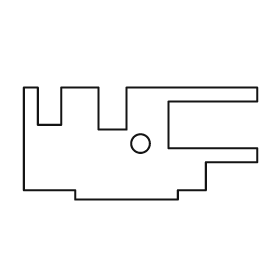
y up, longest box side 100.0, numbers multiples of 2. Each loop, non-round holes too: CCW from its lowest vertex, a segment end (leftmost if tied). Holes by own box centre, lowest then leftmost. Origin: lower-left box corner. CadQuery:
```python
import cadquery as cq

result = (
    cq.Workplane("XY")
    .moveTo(22.0, 0.0)
    .lineTo(66.0, 0.0)
    .lineTo(66.0, 4.0)
    .lineTo(78.0, 4.0)
    .lineTo(78.0, 16.0)
    .lineTo(100.0, 16.0)
    .lineTo(100.0, 22.0)
    .lineTo(62.0, 22.0)
    .lineTo(62.0, 42.0)
    .lineTo(100.0, 42.0)
    .lineTo(100.0, 48.0)
    .lineTo(44.0, 48.0)
    .lineTo(44.0, 30.0)
    .lineTo(32.0, 30.0)
    .lineTo(32.0, 48.0)
    .lineTo(16.0, 48.0)
    .lineTo(16.0, 32.0)
    .lineTo(6.0, 32.0)
    .lineTo(6.0, 48.0)
    .lineTo(0.0, 48.0)
    .lineTo(0.0, 4.0)
    .lineTo(22.0, 4.0)
    .close()
    .moveTo(50.0, 24.0)
    .circle(4.0)
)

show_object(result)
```